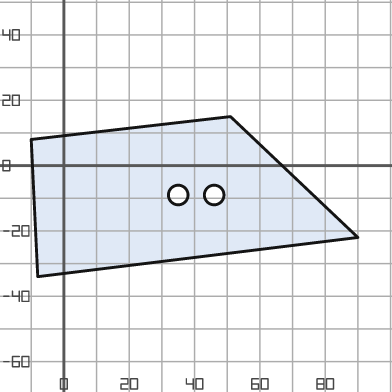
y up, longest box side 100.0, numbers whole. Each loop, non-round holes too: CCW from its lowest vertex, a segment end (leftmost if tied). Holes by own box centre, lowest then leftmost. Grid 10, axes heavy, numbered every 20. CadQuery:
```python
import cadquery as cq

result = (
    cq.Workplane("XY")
    .moveTo(-8.0, -34.0)
    .lineTo(90.0, -22.0)
    .lineTo(51.0, 15.0)
    .lineTo(-10.0, 8.0)
    .close()
    .moveTo(35.0, -9.0)
    .circle(3.0)
    .moveTo(46.0, -9.0)
    .circle(3.0)
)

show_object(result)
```